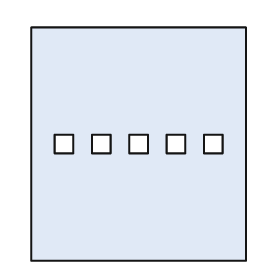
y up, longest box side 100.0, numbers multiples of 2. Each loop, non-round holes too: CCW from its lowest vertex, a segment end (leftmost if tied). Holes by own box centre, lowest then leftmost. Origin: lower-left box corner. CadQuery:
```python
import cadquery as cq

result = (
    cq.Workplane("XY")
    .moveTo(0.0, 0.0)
    .lineTo(92.0, 0.0)
    .lineTo(92.0, 100.0)
    .lineTo(0.0, 100.0)
    .close()
    .moveTo(10.0, 46.0)
    .lineTo(18.0, 46.0)
    .lineTo(18.0, 54.0)
    .lineTo(10.0, 54.0)
    .close()
    .moveTo(26.0, 46.0)
    .lineTo(34.0, 46.0)
    .lineTo(34.0, 54.0)
    .lineTo(26.0, 54.0)
    .close()
    .moveTo(42.0, 46.0)
    .lineTo(50.0, 46.0)
    .lineTo(50.0, 54.0)
    .lineTo(42.0, 54.0)
    .close()
    .moveTo(58.0, 46.0)
    .lineTo(66.0, 46.0)
    .lineTo(66.0, 54.0)
    .lineTo(58.0, 54.0)
    .close()
    .moveTo(74.0, 46.0)
    .lineTo(82.0, 46.0)
    .lineTo(82.0, 54.0)
    .lineTo(74.0, 54.0)
    .close()
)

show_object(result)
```